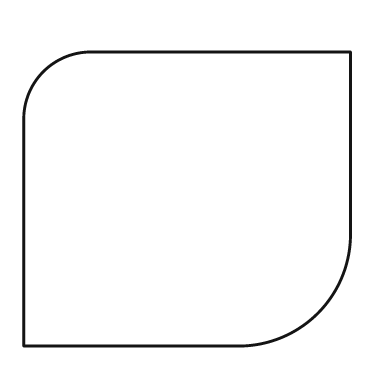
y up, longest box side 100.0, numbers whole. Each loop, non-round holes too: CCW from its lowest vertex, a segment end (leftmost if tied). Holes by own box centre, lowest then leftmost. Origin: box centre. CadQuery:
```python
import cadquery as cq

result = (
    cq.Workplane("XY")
    .moveTo(-50.0, -45.0)
    .lineTo(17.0, -45.0)
    .threePointArc((40.0, -35.0), (50.0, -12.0))
    .lineTo(50.0, 45.0)
    .lineTo(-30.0, 45.0)
    .threePointArc((-44.0, 39.0), (-50.0, 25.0))
    .close()
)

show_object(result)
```